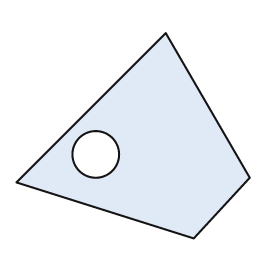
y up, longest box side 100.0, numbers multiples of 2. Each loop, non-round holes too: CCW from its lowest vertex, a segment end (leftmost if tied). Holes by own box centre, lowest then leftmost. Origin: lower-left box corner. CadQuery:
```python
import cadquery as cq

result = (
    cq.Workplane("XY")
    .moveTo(76.0, 0.0)
    .lineTo(100.0, 26.0)
    .lineTo(64.0, 88.0)
    .lineTo(0.0, 24.0)
    .close()
    .moveTo(34.0, 36.0)
    .circle(10.0)
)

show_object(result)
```